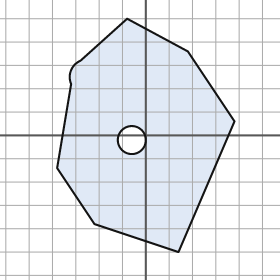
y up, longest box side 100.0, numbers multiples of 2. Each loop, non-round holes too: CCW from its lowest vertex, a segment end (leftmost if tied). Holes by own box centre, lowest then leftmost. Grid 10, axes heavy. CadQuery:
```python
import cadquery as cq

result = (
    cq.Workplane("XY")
    .moveTo(14.0, -50.0)
    .lineTo(38.0, 6.0)
    .lineTo(18.0, 36.0)
    .lineTo(-8.0, 50.0)
    .lineTo(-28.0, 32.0)
    .threePointArc((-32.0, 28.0), (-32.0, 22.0))
    .lineTo(-38.0, -14.0)
    .lineTo(-22.0, -38.0)
    .close()
    .moveTo(-6.0, -2.0)
    .circle(6.0)
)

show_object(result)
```